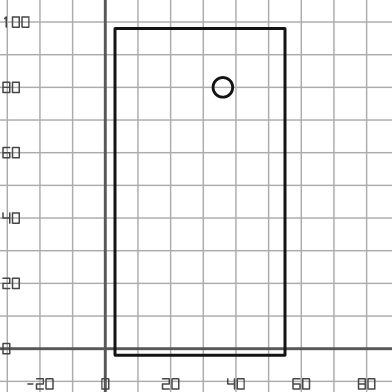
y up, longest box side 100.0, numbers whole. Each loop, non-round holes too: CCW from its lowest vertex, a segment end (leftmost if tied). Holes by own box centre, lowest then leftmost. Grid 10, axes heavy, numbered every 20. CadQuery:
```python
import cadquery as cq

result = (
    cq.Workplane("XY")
    .moveTo(3.0, -2.0)
    .lineTo(55.0, -2.0)
    .lineTo(55.0, 98.0)
    .lineTo(3.0, 98.0)
    .close()
    .moveTo(36.0, 80.0)
    .circle(3.0)
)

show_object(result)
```